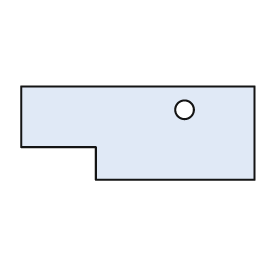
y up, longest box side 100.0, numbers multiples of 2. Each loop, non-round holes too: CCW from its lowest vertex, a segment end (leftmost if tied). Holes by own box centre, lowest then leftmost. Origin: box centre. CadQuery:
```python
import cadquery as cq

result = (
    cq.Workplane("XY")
    .moveTo(-18.0, -20.0)
    .lineTo(50.0, -20.0)
    .lineTo(50.0, 20.0)
    .lineTo(-50.0, 20.0)
    .lineTo(-50.0, -6.0)
    .lineTo(-18.0, -6.0)
    .close()
    .moveTo(20.0, 10.0)
    .circle(4.0)
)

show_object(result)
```